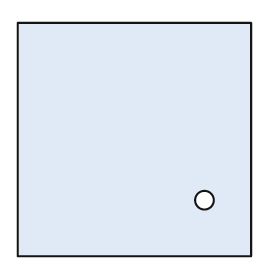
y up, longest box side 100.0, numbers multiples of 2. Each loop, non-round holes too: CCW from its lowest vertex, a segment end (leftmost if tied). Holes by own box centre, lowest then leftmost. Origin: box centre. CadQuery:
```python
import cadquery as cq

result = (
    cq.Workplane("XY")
    .moveTo(-50.0, -50.0)
    .lineTo(50.0, -50.0)
    .lineTo(50.0, 50.0)
    .lineTo(-50.0, 50.0)
    .close()
    .moveTo(30.0, -26.0)
    .circle(4.0)
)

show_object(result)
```